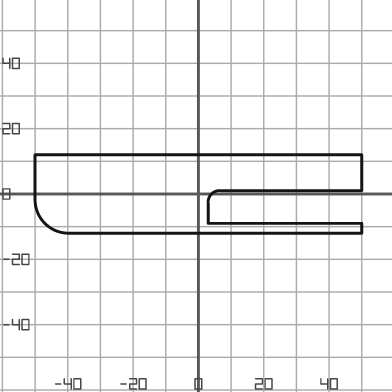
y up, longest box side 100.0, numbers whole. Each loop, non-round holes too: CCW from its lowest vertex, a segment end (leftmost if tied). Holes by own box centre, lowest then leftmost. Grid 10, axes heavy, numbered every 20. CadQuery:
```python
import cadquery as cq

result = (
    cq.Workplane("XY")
    .moveTo(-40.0, -12.0)
    .lineTo(50.0, -12.0)
    .lineTo(50.0, -9.0)
    .lineTo(3.0, -9.0)
    .lineTo(3.0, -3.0)
    .threePointArc((4.0, 0.0), (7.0, 1.0))
    .lineTo(50.0, 1.0)
    .lineTo(50.0, 12.0)
    .lineTo(-50.0, 12.0)
    .lineTo(-50.0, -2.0)
    .threePointArc((-47.0, -9.0), (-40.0, -12.0))
    .close()
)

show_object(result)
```